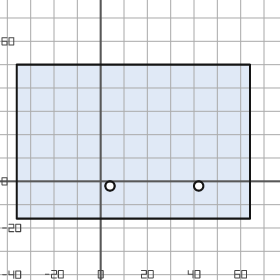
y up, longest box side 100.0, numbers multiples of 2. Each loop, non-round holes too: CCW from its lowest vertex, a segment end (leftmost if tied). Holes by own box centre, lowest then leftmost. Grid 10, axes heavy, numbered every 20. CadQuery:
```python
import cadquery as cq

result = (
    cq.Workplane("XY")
    .moveTo(-36.0, -16.0)
    .lineTo(64.0, -16.0)
    .lineTo(64.0, 50.0)
    .lineTo(-36.0, 50.0)
    .close()
    .moveTo(4.0, -2.0)
    .circle(2.0)
    .moveTo(42.0, -2.0)
    .circle(2.0)
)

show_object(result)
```